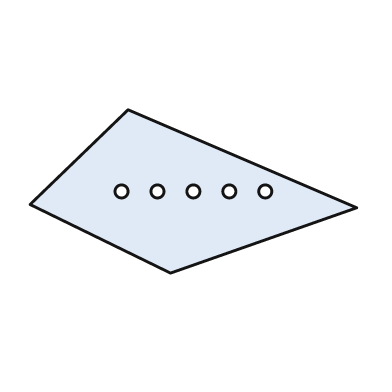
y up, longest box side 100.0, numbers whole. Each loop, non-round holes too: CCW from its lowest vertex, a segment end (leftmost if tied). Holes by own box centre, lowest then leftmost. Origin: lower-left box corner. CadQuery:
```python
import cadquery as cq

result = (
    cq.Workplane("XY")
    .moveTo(43.0, 0.0)
    .lineTo(100.0, 20.0)
    .lineTo(30.0, 50.0)
    .lineTo(0.0, 21.0)
    .close()
    .moveTo(28.0, 25.0)
    .circle(2.0)
    .moveTo(39.0, 25.0)
    .circle(2.0)
    .moveTo(50.0, 25.0)
    .circle(2.0)
    .moveTo(61.0, 25.0)
    .circle(2.0)
    .moveTo(72.0, 25.0)
    .circle(2.0)
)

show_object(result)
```